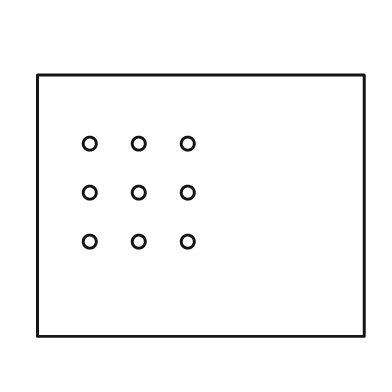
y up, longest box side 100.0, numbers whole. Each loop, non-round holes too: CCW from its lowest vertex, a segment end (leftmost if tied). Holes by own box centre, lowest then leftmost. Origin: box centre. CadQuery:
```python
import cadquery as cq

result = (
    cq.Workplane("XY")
    .moveTo(-50.0, -40.0)
    .lineTo(50.0, -40.0)
    .lineTo(50.0, 40.0)
    .lineTo(-50.0, 40.0)
    .close()
    .moveTo(-34.0, -11.0)
    .circle(2.0)
    .moveTo(-19.0, -11.0)
    .circle(2.0)
    .moveTo(-4.0, -11.0)
    .circle(2.0)
    .moveTo(-34.0, 4.0)
    .circle(2.0)
    .moveTo(-19.0, 4.0)
    .circle(2.0)
    .moveTo(-4.0, 4.0)
    .circle(2.0)
    .moveTo(-34.0, 19.0)
    .circle(2.0)
    .moveTo(-19.0, 19.0)
    .circle(2.0)
    .moveTo(-4.0, 19.0)
    .circle(2.0)
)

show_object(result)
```